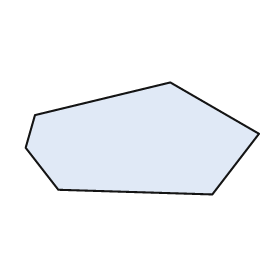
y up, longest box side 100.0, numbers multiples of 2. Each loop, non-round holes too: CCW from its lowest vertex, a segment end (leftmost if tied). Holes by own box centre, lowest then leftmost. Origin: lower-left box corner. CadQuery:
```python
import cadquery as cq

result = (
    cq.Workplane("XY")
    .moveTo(80.0, 0.0)
    .lineTo(100.0, 26.0)
    .lineTo(62.0, 48.0)
    .lineTo(4.0, 34.0)
    .lineTo(0.0, 20.0)
    .lineTo(14.0, 2.0)
    .close()
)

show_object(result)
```